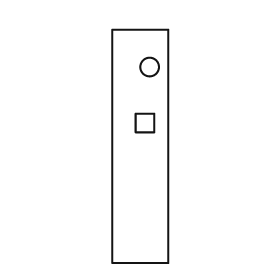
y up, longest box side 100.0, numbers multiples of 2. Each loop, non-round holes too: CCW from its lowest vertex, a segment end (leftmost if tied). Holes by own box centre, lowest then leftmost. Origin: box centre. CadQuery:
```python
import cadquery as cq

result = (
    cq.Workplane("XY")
    .moveTo(-12.0, -50.0)
    .lineTo(12.0, -50.0)
    .lineTo(12.0, 50.0)
    .lineTo(-12.0, 50.0)
    .close()
    .moveTo(-2.0, 6.0)
    .lineTo(6.0, 6.0)
    .lineTo(6.0, 14.0)
    .lineTo(-2.0, 14.0)
    .close()
    .moveTo(4.0, 34.0)
    .circle(4.0)
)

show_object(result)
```